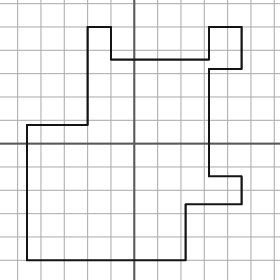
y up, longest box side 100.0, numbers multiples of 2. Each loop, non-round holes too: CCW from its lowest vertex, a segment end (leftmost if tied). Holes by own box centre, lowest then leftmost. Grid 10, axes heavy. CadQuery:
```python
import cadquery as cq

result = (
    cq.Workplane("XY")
    .moveTo(-46.0, -50.0)
    .lineTo(22.0, -50.0)
    .lineTo(22.0, -26.0)
    .lineTo(46.0, -26.0)
    .lineTo(46.0, -14.0)
    .lineTo(32.0, -14.0)
    .lineTo(32.0, 32.0)
    .lineTo(46.0, 32.0)
    .lineTo(46.0, 50.0)
    .lineTo(32.0, 50.0)
    .lineTo(32.0, 36.0)
    .lineTo(-10.0, 36.0)
    .lineTo(-10.0, 50.0)
    .lineTo(-20.0, 50.0)
    .lineTo(-20.0, 8.0)
    .lineTo(-46.0, 8.0)
    .close()
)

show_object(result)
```